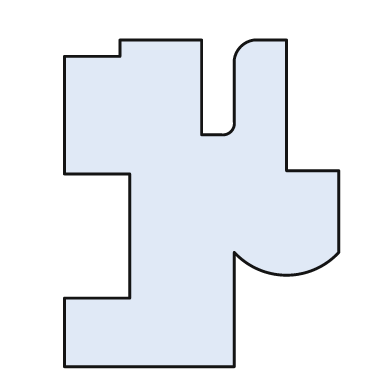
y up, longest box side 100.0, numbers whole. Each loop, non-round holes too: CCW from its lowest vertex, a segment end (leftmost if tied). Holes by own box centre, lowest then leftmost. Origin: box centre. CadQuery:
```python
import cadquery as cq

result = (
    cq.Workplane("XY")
    .moveTo(-42.0, -50.0)
    .lineTo(10.0, -50.0)
    .lineTo(10.0, -15.0)
    .threePointArc((26.0, -22.0), (42.0, -15.0))
    .lineTo(42.0, 10.0)
    .lineTo(26.0, 10.0)
    .lineTo(26.0, 50.0)
    .lineTo(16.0, 50.0)
    .threePointArc((12.0, 48.0), (10.0, 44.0))
    .lineTo(10.0, 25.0)
    .threePointArc((9.0, 22.0), (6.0, 21.0))
    .lineTo(0.0, 21.0)
    .lineTo(0.0, 50.0)
    .lineTo(-25.0, 50.0)
    .lineTo(-25.0, 45.0)
    .lineTo(-42.0, 45.0)
    .lineTo(-42.0, 9.0)
    .lineTo(-22.0, 9.0)
    .lineTo(-22.0, -29.0)
    .lineTo(-42.0, -29.0)
    .close()
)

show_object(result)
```